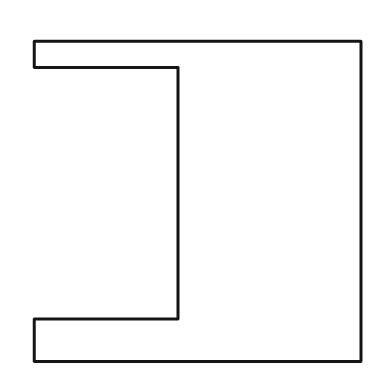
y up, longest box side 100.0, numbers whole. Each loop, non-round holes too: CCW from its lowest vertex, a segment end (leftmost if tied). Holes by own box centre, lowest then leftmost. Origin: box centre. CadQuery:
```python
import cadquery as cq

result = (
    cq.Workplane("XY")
    .moveTo(-50.0, -49.0)
    .lineTo(50.0, -49.0)
    .lineTo(50.0, 49.0)
    .lineTo(-50.0, 49.0)
    .lineTo(-50.0, 41.0)
    .lineTo(-6.0, 41.0)
    .lineTo(-6.0, -36.0)
    .lineTo(-50.0, -36.0)
    .close()
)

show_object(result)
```